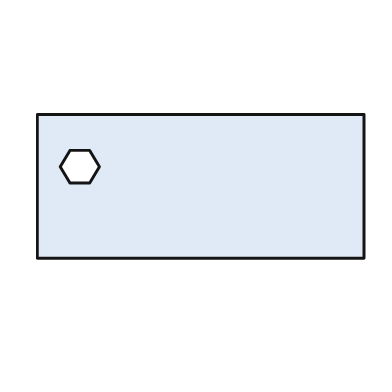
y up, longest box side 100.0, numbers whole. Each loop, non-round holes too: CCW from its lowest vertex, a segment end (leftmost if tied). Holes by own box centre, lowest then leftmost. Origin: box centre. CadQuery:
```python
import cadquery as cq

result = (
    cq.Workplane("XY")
    .moveTo(-50.0, -22.0)
    .lineTo(50.0, -22.0)
    .lineTo(50.0, 22.0)
    .lineTo(-50.0, 22.0)
    .close()
    .moveTo(-40.0, 1.0)
    .lineTo(-34.0, 1.0)
    .lineTo(-31.0, 6.0)
    .lineTo(-34.0, 11.0)
    .lineTo(-40.0, 11.0)
    .lineTo(-43.0, 6.0)
    .close()
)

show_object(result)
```